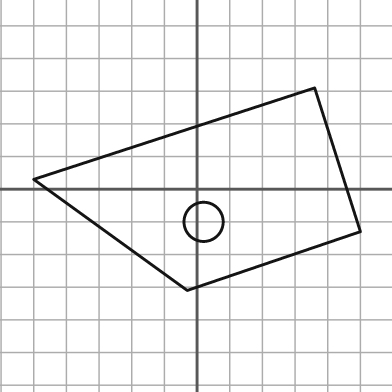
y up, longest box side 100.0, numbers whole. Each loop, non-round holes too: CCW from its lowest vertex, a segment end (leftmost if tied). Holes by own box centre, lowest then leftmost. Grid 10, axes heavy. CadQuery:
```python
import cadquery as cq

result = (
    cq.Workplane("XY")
    .moveTo(-3.0, -31.0)
    .lineTo(50.0, -13.0)
    .lineTo(36.0, 31.0)
    .lineTo(-50.0, 3.0)
    .close()
    .moveTo(2.0, -10.0)
    .circle(6.0)
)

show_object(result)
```